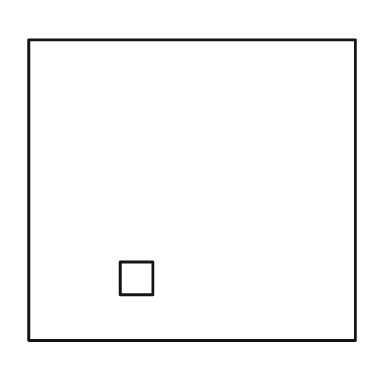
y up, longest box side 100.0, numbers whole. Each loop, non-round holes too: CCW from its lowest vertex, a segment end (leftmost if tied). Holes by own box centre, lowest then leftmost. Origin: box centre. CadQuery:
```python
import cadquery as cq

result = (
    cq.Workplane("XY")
    .moveTo(-50.0, -46.0)
    .lineTo(50.0, -46.0)
    .lineTo(50.0, 46.0)
    .lineTo(-50.0, 46.0)
    .close()
    .moveTo(-22.0, -32.0)
    .lineTo(-12.0, -32.0)
    .lineTo(-12.0, -22.0)
    .lineTo(-22.0, -22.0)
    .close()
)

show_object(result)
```